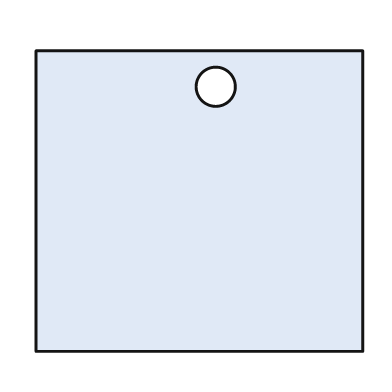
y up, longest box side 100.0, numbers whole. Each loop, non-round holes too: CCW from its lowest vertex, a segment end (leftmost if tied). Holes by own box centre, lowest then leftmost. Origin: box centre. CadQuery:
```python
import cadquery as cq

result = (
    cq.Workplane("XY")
    .moveTo(-50.0, -46.0)
    .lineTo(50.0, -46.0)
    .lineTo(50.0, 46.0)
    .lineTo(-50.0, 46.0)
    .close()
    .moveTo(5.0, 35.0)
    .circle(6.0)
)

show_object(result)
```